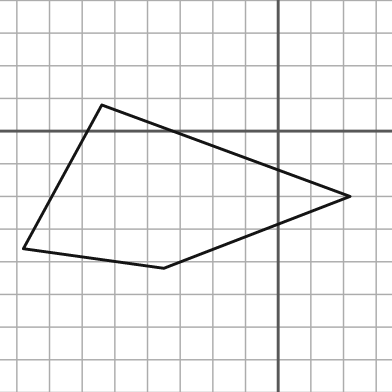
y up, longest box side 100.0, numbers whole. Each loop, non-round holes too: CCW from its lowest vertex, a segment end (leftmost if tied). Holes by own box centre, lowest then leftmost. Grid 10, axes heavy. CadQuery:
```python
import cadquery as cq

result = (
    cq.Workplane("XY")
    .moveTo(-35.0, -42.0)
    .lineTo(22.0, -20.0)
    .lineTo(-54.0, 8.0)
    .lineTo(-78.0, -36.0)
    .close()
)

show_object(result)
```